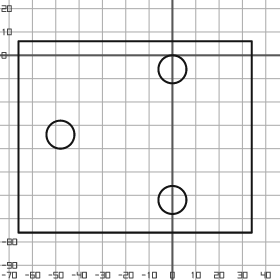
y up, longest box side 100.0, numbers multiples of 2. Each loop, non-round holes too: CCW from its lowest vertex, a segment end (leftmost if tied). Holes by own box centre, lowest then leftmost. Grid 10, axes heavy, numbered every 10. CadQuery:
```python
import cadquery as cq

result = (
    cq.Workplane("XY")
    .moveTo(-66.0, -76.0)
    .lineTo(34.0, -76.0)
    .lineTo(34.0, 6.0)
    .lineTo(-66.0, 6.0)
    .close()
    .moveTo(0.0, -62.0)
    .circle(6.0)
    .moveTo(-48.0, -34.0)
    .circle(6.0)
    .moveTo(0.0, -6.0)
    .circle(6.0)
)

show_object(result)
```